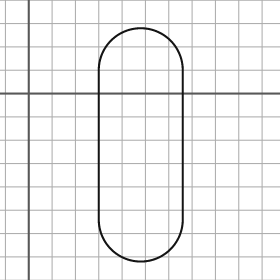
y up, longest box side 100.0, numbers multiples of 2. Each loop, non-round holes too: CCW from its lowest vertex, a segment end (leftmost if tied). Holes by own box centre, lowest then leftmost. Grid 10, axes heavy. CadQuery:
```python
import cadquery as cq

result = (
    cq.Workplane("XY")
    .moveTo(30.0, -54.0)
    .threePointArc((48.0, -72.0), (66.0, -54.0))
    .lineTo(66.0, 10.0)
    .threePointArc((48.0, 28.0), (30.0, 10.0))
    .close()
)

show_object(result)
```